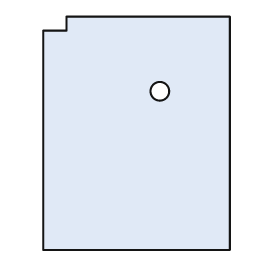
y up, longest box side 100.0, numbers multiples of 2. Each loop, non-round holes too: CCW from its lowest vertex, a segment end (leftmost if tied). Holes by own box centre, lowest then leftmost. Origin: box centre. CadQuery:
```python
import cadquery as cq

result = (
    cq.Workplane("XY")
    .moveTo(-40.0, -50.0)
    .lineTo(40.0, -50.0)
    .lineTo(40.0, 50.0)
    .lineTo(-30.0, 50.0)
    .lineTo(-30.0, 44.0)
    .lineTo(-40.0, 44.0)
    .close()
    .moveTo(10.0, 18.0)
    .circle(4.0)
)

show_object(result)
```